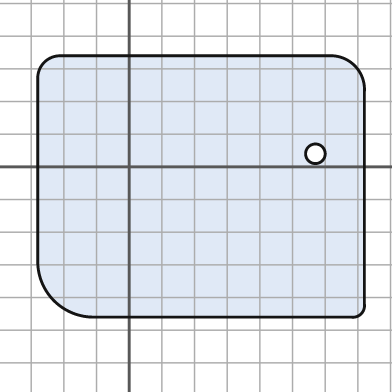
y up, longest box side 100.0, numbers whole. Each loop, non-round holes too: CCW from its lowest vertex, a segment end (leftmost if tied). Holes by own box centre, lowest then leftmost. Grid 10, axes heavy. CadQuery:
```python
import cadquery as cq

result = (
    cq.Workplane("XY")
    .moveTo(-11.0, -46.0)
    .lineTo(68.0, -46.0)
    .threePointArc((71.0, -45.0), (72.0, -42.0))
    .lineTo(72.0, 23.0)
    .threePointArc((69.0, 31.0), (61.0, 34.0))
    .lineTo(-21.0, 34.0)
    .threePointArc((-26.0, 32.0), (-28.0, 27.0))
    .lineTo(-28.0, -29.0)
    .threePointArc((-23.0, -41.0), (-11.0, -46.0))
    .close()
    .moveTo(57.0, 4.0)
    .circle(3.0)
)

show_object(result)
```